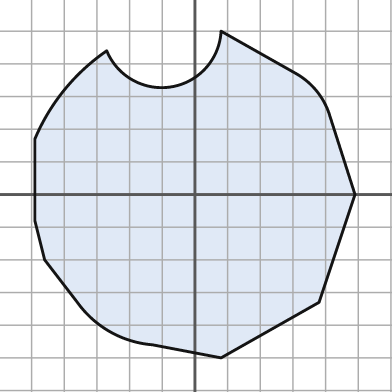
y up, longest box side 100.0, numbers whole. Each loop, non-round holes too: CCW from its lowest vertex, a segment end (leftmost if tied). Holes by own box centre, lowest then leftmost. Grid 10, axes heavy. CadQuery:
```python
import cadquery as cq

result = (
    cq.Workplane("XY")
    .moveTo(8.0, -50.0)
    .lineTo(38.0, -33.0)
    .lineTo(49.0, 0.0)
    .lineTo(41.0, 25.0)
    .threePointArc((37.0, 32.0), (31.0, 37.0))
    .lineTo(8.0, 50.0)
    .threePointArc((-7.0, 33.0), (-27.0, 44.0))
    .threePointArc((-40.0, 32.0), (-49.0, 17.0))
    .lineTo(-49.0, -8.0)
    .lineTo(-46.0, -20.0)
    .lineTo(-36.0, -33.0)
    .threePointArc((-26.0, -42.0), (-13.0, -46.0))
    .close()
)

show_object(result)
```